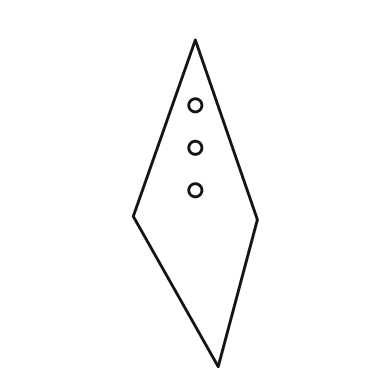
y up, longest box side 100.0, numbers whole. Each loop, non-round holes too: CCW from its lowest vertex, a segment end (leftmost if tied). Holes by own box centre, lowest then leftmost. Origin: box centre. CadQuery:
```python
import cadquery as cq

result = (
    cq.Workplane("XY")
    .moveTo(7.0, -50.0)
    .lineTo(19.0, -5.0)
    .lineTo(0.0, 50.0)
    .lineTo(-19.0, -4.0)
    .close()
    .moveTo(0.0, 4.0)
    .circle(2.0)
    .moveTo(0.0, 17.0)
    .circle(2.0)
    .moveTo(0.0, 30.0)
    .circle(2.0)
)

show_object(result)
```